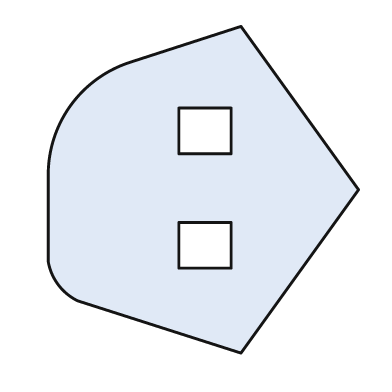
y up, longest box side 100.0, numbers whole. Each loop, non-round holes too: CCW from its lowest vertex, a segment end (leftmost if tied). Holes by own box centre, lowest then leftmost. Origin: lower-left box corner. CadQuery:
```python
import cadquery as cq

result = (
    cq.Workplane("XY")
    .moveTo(59.0, 0.0)
    .lineTo(95.0, 50.0)
    .lineTo(59.0, 100.0)
    .lineTo(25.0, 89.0)
    .threePointArc((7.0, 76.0), (0.0, 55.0))
    .lineTo(0.0, 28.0)
    .threePointArc((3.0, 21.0), (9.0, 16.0))
    .close()
    .moveTo(40.0, 26.0)
    .lineTo(56.0, 26.0)
    .lineTo(56.0, 40.0)
    .lineTo(40.0, 40.0)
    .close()
    .moveTo(40.0, 61.0)
    .lineTo(56.0, 61.0)
    .lineTo(56.0, 75.0)
    .lineTo(40.0, 75.0)
    .close()
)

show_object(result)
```